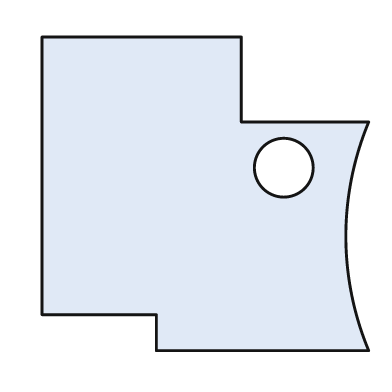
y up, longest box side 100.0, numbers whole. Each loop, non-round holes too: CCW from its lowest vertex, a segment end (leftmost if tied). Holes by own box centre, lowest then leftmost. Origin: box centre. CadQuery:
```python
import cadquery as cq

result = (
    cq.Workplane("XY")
    .moveTo(-15.0, -48.0)
    .lineTo(50.0, -48.0)
    .threePointArc((43.0, -13.0), (50.0, 22.0))
    .lineTo(11.0, 22.0)
    .lineTo(11.0, 48.0)
    .lineTo(-50.0, 48.0)
    .lineTo(-50.0, -37.0)
    .lineTo(-15.0, -37.0)
    .close()
    .moveTo(24.0, 8.0)
    .circle(9.0)
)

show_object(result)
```